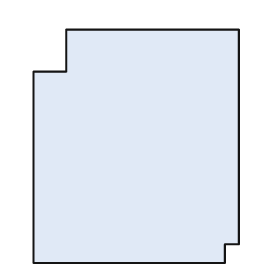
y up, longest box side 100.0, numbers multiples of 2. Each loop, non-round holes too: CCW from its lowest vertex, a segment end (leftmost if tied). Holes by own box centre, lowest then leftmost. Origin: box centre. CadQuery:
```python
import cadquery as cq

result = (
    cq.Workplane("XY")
    .moveTo(-44.0, -50.0)
    .lineTo(38.0, -50.0)
    .lineTo(38.0, -42.0)
    .lineTo(44.0, -42.0)
    .lineTo(44.0, 50.0)
    .lineTo(-30.0, 50.0)
    .lineTo(-30.0, 32.0)
    .lineTo(-44.0, 32.0)
    .close()
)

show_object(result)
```